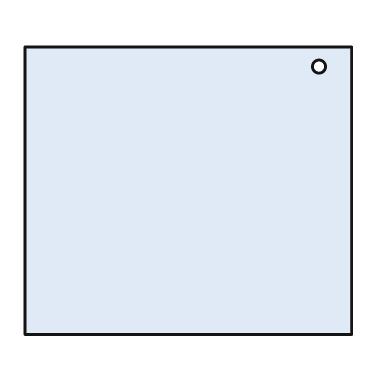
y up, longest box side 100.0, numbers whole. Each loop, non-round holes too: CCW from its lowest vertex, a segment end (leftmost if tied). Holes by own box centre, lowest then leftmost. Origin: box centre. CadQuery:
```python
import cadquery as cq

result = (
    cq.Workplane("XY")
    .moveTo(-50.0, -44.0)
    .lineTo(50.0, -44.0)
    .lineTo(50.0, 44.0)
    .lineTo(-50.0, 44.0)
    .close()
    .moveTo(40.0, 38.0)
    .circle(2.0)
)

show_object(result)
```